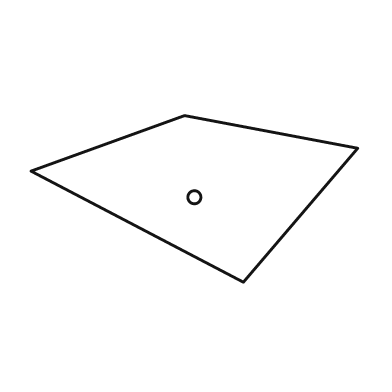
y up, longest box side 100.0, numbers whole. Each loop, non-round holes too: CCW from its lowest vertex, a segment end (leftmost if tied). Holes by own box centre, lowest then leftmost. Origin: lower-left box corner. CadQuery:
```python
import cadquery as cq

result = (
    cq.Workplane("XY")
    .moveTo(65.0, 0.0)
    .lineTo(100.0, 41.0)
    .lineTo(47.0, 51.0)
    .lineTo(0.0, 34.0)
    .close()
    .moveTo(50.0, 26.0)
    .circle(2.0)
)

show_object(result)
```